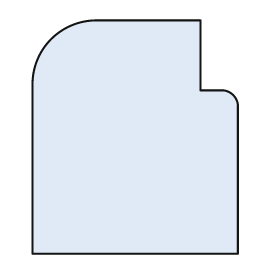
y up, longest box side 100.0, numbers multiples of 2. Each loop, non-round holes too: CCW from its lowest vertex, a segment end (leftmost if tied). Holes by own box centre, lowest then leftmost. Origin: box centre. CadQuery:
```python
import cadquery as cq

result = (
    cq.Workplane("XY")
    .moveTo(-44.0, -50.0)
    .lineTo(44.0, -50.0)
    .lineTo(44.0, 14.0)
    .threePointArc((42.0, 18.0), (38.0, 20.0))
    .lineTo(28.0, 20.0)
    .lineTo(28.0, 50.0)
    .lineTo(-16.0, 50.0)
    .threePointArc((-36.0, 42.0), (-44.0, 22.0))
    .close()
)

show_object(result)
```